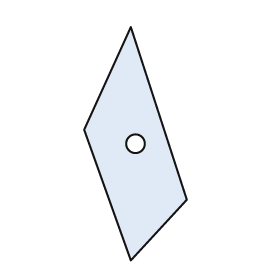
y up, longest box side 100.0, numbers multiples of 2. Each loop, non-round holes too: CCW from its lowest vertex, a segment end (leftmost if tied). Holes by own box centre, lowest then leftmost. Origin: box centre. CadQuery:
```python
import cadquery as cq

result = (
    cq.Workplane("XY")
    .moveTo(-2.0, -50.0)
    .lineTo(22.0, -24.0)
    .lineTo(-2.0, 50.0)
    .lineTo(-22.0, 6.0)
    .close()
    .moveTo(0.0, 0.0)
    .circle(4.0)
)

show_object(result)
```